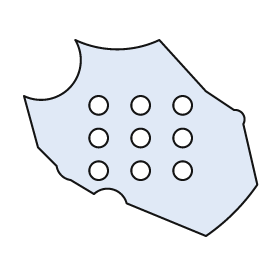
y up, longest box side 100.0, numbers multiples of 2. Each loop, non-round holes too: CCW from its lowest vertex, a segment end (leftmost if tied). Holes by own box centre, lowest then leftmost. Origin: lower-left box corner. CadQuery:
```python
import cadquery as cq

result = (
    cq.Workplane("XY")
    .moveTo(78.0, 0.0)
    .threePointArc((90.0, 10.0), (100.0, 22.0))
    .lineTo(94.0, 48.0)
    .threePointArc((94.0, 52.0), (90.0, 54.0))
    .lineTo(78.0, 62.0)
    .lineTo(58.0, 84.0)
    .threePointArc((40.0, 80.0), (22.0, 84.0))
    .threePointArc((20.0, 64.0), (0.0, 60.0))
    .lineTo(6.0, 38.0)
    .lineTo(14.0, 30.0)
    .threePointArc((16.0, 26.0), (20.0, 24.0))
    .lineTo(30.0, 18.0)
    .threePointArc((38.0, 20.0), (44.0, 14.0))
    .close()
    .moveTo(32.0, 28.0)
    .circle(4.0)
    .moveTo(50.0, 28.0)
    .circle(4.0)
    .moveTo(68.0, 28.0)
    .circle(4.0)
    .moveTo(32.0, 42.0)
    .circle(4.0)
    .moveTo(50.0, 42.0)
    .circle(4.0)
    .moveTo(68.0, 42.0)
    .circle(4.0)
    .moveTo(32.0, 56.0)
    .circle(4.0)
    .moveTo(50.0, 56.0)
    .circle(4.0)
    .moveTo(68.0, 56.0)
    .circle(4.0)
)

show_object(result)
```